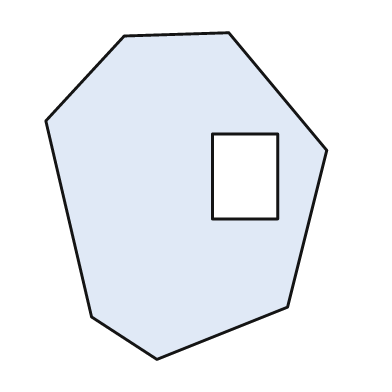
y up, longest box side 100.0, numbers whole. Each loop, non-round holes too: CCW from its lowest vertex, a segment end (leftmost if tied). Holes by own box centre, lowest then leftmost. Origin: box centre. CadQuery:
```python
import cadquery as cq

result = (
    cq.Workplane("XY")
    .moveTo(-9.0, -50.0)
    .lineTo(31.0, -34.0)
    .lineTo(43.0, 14.0)
    .lineTo(13.0, 50.0)
    .lineTo(-19.0, 49.0)
    .lineTo(-43.0, 23.0)
    .lineTo(-29.0, -37.0)
    .close()
    .moveTo(8.0, -7.0)
    .lineTo(28.0, -7.0)
    .lineTo(28.0, 19.0)
    .lineTo(8.0, 19.0)
    .close()
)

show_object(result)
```